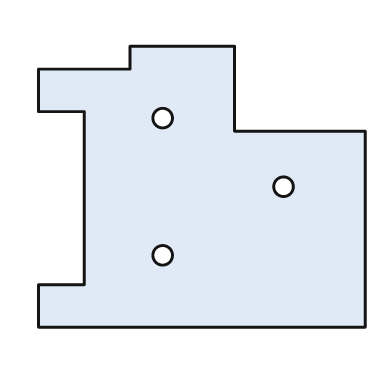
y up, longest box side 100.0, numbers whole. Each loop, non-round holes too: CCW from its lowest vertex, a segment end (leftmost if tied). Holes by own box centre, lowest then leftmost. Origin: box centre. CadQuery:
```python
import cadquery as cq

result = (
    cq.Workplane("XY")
    .moveTo(-50.0, -43.0)
    .lineTo(50.0, -43.0)
    .lineTo(50.0, 17.0)
    .lineTo(10.0, 17.0)
    .lineTo(10.0, 43.0)
    .lineTo(-22.0, 43.0)
    .lineTo(-22.0, 36.0)
    .lineTo(-50.0, 36.0)
    .lineTo(-50.0, 23.0)
    .lineTo(-36.0, 23.0)
    .lineTo(-36.0, -30.0)
    .lineTo(-50.0, -30.0)
    .close()
    .moveTo(-12.0, -21.0)
    .circle(3.0)
    .moveTo(25.0, 0.0)
    .circle(3.0)
    .moveTo(-12.0, 21.0)
    .circle(3.0)
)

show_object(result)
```